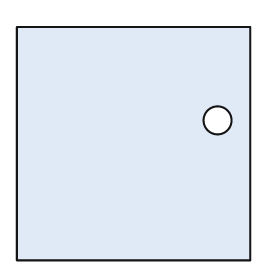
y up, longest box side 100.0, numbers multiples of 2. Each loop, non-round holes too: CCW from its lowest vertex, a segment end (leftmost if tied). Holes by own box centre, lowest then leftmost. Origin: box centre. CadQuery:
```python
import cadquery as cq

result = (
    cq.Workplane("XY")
    .moveTo(-50.0, -50.0)
    .lineTo(50.0, -50.0)
    .lineTo(50.0, 50.0)
    .lineTo(-50.0, 50.0)
    .close()
    .moveTo(36.0, 10.0)
    .circle(6.0)
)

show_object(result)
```